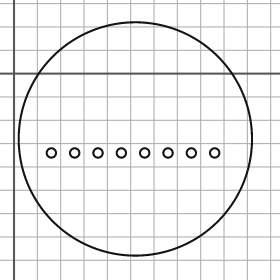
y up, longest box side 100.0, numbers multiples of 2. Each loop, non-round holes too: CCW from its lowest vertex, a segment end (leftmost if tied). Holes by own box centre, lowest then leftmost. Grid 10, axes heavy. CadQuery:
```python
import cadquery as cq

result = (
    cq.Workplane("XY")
    .moveTo(52.0, -28.0)
    .circle(50.0)
    .moveTo(16.0, -34.0)
    .circle(2.0)
    .moveTo(26.0, -34.0)
    .circle(2.0)
    .moveTo(36.0, -34.0)
    .circle(2.0)
    .moveTo(46.0, -34.0)
    .circle(2.0)
    .moveTo(56.0, -34.0)
    .circle(2.0)
    .moveTo(66.0, -34.0)
    .circle(2.0)
    .moveTo(76.0, -34.0)
    .circle(2.0)
    .moveTo(86.0, -34.0)
    .circle(2.0)
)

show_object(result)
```